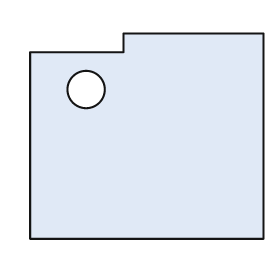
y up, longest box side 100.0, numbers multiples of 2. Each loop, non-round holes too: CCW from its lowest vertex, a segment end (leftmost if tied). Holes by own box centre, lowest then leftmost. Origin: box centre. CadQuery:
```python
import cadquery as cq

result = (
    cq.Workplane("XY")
    .moveTo(-50.0, -44.0)
    .lineTo(50.0, -44.0)
    .lineTo(50.0, 44.0)
    .lineTo(-10.0, 44.0)
    .lineTo(-10.0, 36.0)
    .lineTo(-50.0, 36.0)
    .close()
    .moveTo(-26.0, 20.0)
    .circle(8.0)
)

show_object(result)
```